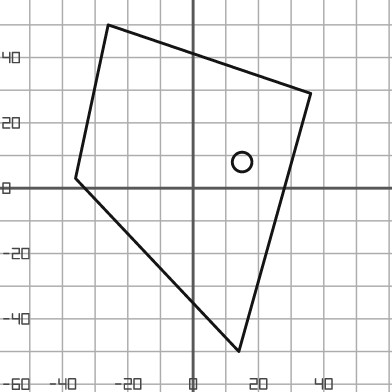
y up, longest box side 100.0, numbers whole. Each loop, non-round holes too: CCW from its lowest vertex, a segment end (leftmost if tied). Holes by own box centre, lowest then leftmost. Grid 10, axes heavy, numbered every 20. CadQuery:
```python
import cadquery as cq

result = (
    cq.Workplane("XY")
    .moveTo(14.0, -50.0)
    .lineTo(36.0, 29.0)
    .lineTo(-26.0, 50.0)
    .lineTo(-36.0, 3.0)
    .close()
    .moveTo(15.0, 8.0)
    .circle(3.0)
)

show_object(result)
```